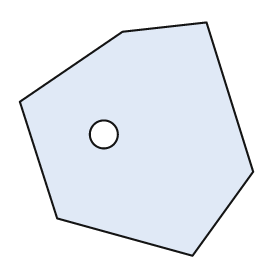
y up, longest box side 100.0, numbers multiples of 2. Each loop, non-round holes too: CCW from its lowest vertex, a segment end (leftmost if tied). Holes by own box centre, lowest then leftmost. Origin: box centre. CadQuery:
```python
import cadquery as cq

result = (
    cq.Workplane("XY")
    .moveTo(24.0, -50.0)
    .lineTo(50.0, -14.0)
    .lineTo(30.0, 50.0)
    .lineTo(-6.0, 46.0)
    .lineTo(-50.0, 16.0)
    .lineTo(-34.0, -34.0)
    .close()
    .moveTo(-14.0, 2.0)
    .circle(6.0)
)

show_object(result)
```